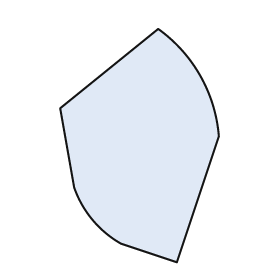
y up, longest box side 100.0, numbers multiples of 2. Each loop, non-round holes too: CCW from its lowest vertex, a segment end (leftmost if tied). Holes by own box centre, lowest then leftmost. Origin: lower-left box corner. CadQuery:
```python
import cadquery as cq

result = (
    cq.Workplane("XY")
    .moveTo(50.0, 0.0)
    .lineTo(68.0, 54.0)
    .threePointArc((60.0, 80.0), (42.0, 100.0))
    .lineTo(0.0, 66.0)
    .lineTo(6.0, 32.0)
    .threePointArc((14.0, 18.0), (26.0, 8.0))
    .close()
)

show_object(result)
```